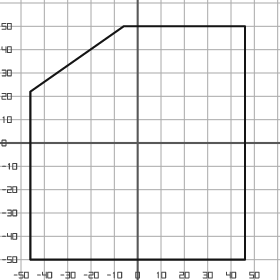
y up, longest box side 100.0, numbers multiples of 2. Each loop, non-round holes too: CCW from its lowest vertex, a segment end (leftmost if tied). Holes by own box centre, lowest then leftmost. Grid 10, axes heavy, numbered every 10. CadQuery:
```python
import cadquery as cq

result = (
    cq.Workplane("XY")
    .moveTo(-46.0, -50.0)
    .lineTo(46.0, -50.0)
    .lineTo(46.0, 50.0)
    .lineTo(-6.0, 50.0)
    .lineTo(-46.0, 22.0)
    .close()
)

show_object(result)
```